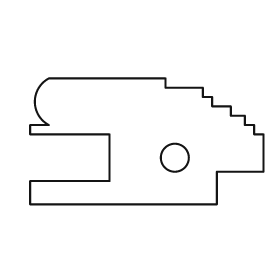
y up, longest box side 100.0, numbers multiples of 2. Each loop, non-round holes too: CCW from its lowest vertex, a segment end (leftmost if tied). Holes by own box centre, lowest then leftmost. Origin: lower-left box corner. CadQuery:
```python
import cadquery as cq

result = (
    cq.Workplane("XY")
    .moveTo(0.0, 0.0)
    .lineTo(80.0, 0.0)
    .lineTo(80.0, 14.0)
    .lineTo(100.0, 14.0)
    .lineTo(100.0, 30.0)
    .lineTo(96.0, 30.0)
    .lineTo(96.0, 34.0)
    .lineTo(92.0, 34.0)
    .lineTo(92.0, 38.0)
    .lineTo(86.0, 38.0)
    .lineTo(86.0, 42.0)
    .lineTo(78.0, 42.0)
    .lineTo(78.0, 46.0)
    .lineTo(74.0, 46.0)
    .lineTo(74.0, 50.0)
    .lineTo(58.0, 50.0)
    .lineTo(58.0, 54.0)
    .lineTo(8.0, 54.0)
    .threePointArc((2.0, 44.0), (8.0, 34.0))
    .lineTo(0.0, 34.0)
    .lineTo(0.0, 30.0)
    .lineTo(34.0, 30.0)
    .lineTo(34.0, 10.0)
    .lineTo(0.0, 10.0)
    .close()
    .moveTo(62.0, 20.0)
    .circle(6.0)
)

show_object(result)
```